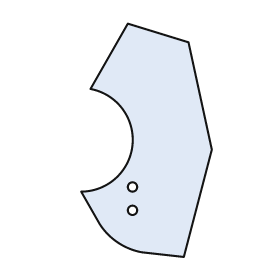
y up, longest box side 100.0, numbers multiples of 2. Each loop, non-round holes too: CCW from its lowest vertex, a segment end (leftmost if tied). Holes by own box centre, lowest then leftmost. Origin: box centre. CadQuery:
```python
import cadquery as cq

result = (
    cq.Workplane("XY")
    .moveTo(16.0, -50.0)
    .lineTo(28.0, -4.0)
    .lineTo(18.0, 42.0)
    .lineTo(-8.0, 50.0)
    .lineTo(-24.0, 22.0)
    .threePointArc((-6.0, -2.0), (-28.0, -22.0))
    .lineTo(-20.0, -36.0)
    .threePointArc((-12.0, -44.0), (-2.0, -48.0))
    .close()
    .moveTo(-6.0, -30.0)
    .circle(2.0)
    .moveTo(-6.0, -20.0)
    .circle(2.0)
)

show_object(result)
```